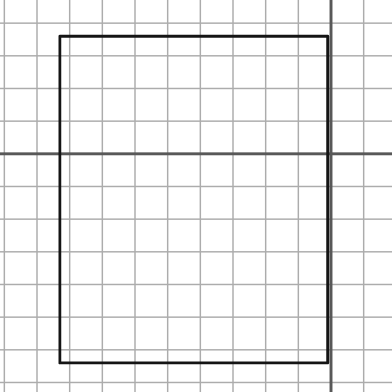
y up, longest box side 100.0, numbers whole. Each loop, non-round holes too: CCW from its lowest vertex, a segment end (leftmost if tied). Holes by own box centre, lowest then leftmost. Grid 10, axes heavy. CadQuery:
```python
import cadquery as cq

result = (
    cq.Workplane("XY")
    .moveTo(-83.0, -64.0)
    .lineTo(-1.0, -64.0)
    .lineTo(-1.0, 36.0)
    .lineTo(-83.0, 36.0)
    .close()
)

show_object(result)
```